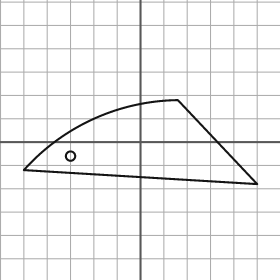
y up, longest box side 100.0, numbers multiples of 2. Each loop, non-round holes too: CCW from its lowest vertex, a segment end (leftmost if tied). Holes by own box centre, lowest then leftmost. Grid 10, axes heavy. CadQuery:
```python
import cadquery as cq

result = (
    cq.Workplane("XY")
    .moveTo(50.0, -18.0)
    .lineTo(16.0, 18.0)
    .threePointArc((-20.0, 10.0), (-50.0, -12.0))
    .close()
    .moveTo(-30.0, -6.0)
    .circle(2.0)
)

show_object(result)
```